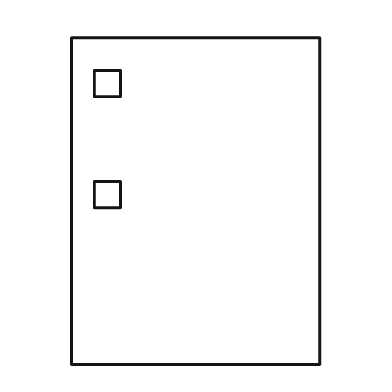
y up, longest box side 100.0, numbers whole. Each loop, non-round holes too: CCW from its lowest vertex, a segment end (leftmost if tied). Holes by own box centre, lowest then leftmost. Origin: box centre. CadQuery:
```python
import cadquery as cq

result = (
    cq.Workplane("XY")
    .moveTo(-38.0, -50.0)
    .lineTo(38.0, -50.0)
    .lineTo(38.0, 50.0)
    .lineTo(-38.0, 50.0)
    .close()
    .moveTo(-31.0, -2.0)
    .lineTo(-23.0, -2.0)
    .lineTo(-23.0, 6.0)
    .lineTo(-31.0, 6.0)
    .close()
    .moveTo(-31.0, 32.0)
    .lineTo(-23.0, 32.0)
    .lineTo(-23.0, 40.0)
    .lineTo(-31.0, 40.0)
    .close()
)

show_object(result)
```